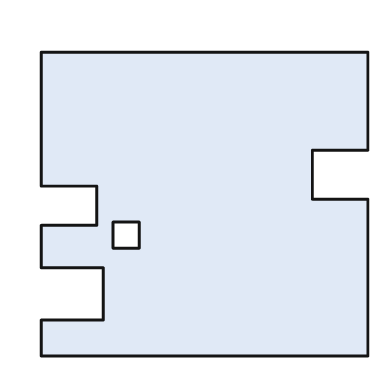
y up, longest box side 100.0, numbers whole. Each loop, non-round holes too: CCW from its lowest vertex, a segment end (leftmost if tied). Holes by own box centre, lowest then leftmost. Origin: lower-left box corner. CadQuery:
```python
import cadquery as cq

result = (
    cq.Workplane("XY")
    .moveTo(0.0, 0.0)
    .lineTo(100.0, 0.0)
    .lineTo(100.0, 48.0)
    .lineTo(83.0, 48.0)
    .lineTo(83.0, 63.0)
    .lineTo(100.0, 63.0)
    .lineTo(100.0, 93.0)
    .lineTo(0.0, 93.0)
    .lineTo(0.0, 52.0)
    .lineTo(17.0, 52.0)
    .lineTo(17.0, 40.0)
    .lineTo(0.0, 40.0)
    .lineTo(0.0, 27.0)
    .lineTo(19.0, 27.0)
    .lineTo(19.0, 11.0)
    .lineTo(0.0, 11.0)
    .close()
    .moveTo(22.0, 33.0)
    .lineTo(30.0, 33.0)
    .lineTo(30.0, 41.0)
    .lineTo(22.0, 41.0)
    .close()
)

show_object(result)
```